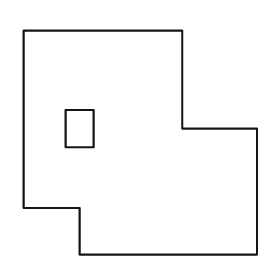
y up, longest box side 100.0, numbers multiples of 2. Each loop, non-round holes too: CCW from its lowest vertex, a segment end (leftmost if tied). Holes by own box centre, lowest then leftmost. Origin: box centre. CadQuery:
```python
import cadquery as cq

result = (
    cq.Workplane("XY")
    .moveTo(-26.0, -48.0)
    .lineTo(50.0, -48.0)
    .lineTo(50.0, 6.0)
    .lineTo(18.0, 6.0)
    .lineTo(18.0, 48.0)
    .lineTo(-50.0, 48.0)
    .lineTo(-50.0, -28.0)
    .lineTo(-26.0, -28.0)
    .close()
    .moveTo(-32.0, -2.0)
    .lineTo(-20.0, -2.0)
    .lineTo(-20.0, 14.0)
    .lineTo(-32.0, 14.0)
    .close()
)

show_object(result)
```